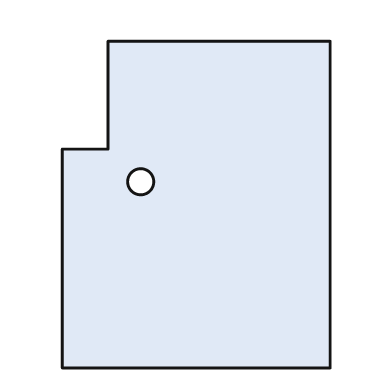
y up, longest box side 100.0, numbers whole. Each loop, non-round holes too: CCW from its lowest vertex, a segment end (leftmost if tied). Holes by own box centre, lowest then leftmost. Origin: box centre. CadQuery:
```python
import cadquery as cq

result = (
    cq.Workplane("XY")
    .moveTo(-41.0, -50.0)
    .lineTo(41.0, -50.0)
    .lineTo(41.0, 50.0)
    .lineTo(-27.0, 50.0)
    .lineTo(-27.0, 17.0)
    .lineTo(-41.0, 17.0)
    .close()
    .moveTo(-17.0, 7.0)
    .circle(4.0)
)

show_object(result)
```